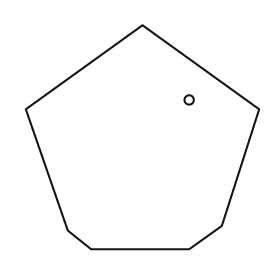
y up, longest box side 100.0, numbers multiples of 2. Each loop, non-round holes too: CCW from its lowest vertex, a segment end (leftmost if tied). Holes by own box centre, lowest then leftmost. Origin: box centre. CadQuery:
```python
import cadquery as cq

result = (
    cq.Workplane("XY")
    .moveTo(-22.0, -48.0)
    .lineTo(20.0, -48.0)
    .lineTo(34.0, -38.0)
    .lineTo(50.0, 12.0)
    .lineTo(0.0, 48.0)
    .lineTo(-50.0, 12.0)
    .lineTo(-32.0, -40.0)
    .close()
    .moveTo(20.0, 16.0)
    .circle(2.0)
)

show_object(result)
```